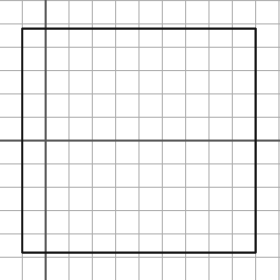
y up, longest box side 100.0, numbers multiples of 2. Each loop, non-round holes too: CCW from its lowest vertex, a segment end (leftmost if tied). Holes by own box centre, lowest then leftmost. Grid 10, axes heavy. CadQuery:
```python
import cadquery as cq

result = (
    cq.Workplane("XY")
    .moveTo(-10.0, -48.0)
    .lineTo(90.0, -48.0)
    .lineTo(90.0, 48.0)
    .lineTo(-10.0, 48.0)
    .close()
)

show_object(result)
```